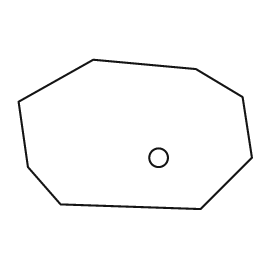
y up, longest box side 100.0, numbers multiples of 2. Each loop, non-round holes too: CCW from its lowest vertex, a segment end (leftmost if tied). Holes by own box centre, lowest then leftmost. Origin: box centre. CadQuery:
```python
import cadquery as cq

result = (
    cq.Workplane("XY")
    .moveTo(28.0, -32.0)
    .lineTo(50.0, -10.0)
    .lineTo(46.0, 16.0)
    .lineTo(26.0, 28.0)
    .lineTo(-18.0, 32.0)
    .lineTo(-50.0, 14.0)
    .lineTo(-46.0, -14.0)
    .lineTo(-32.0, -30.0)
    .close()
    .moveTo(10.0, -10.0)
    .circle(4.0)
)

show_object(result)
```